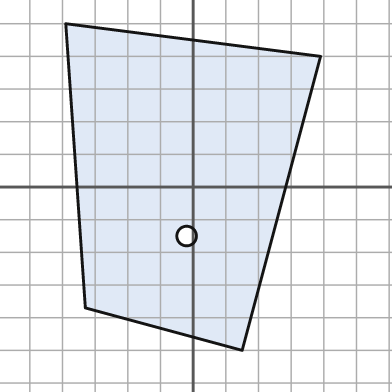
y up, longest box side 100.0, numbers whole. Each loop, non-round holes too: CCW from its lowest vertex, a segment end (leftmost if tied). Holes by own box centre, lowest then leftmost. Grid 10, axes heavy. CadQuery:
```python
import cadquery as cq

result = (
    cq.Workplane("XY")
    .moveTo(15.0, -50.0)
    .lineTo(39.0, 40.0)
    .lineTo(-39.0, 50.0)
    .lineTo(-33.0, -37.0)
    .close()
    .moveTo(-2.0, -15.0)
    .circle(3.0)
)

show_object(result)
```